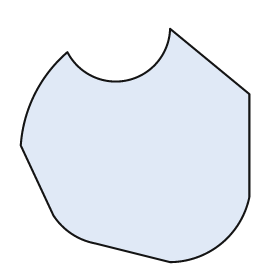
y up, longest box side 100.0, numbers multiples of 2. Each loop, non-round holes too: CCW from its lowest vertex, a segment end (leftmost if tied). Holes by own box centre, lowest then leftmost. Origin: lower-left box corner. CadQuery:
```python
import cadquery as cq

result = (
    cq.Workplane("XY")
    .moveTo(64.0, 0.0)
    .threePointArc((86.0, 8.0), (98.0, 28.0))
    .lineTo(98.0, 72.0)
    .lineTo(64.0, 100.0)
    .threePointArc((46.0, 78.0), (20.0, 90.0))
    .threePointArc((6.0, 72.0), (0.0, 50.0))
    .lineTo(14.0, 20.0)
    .threePointArc((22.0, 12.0), (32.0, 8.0))
    .close()
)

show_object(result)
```